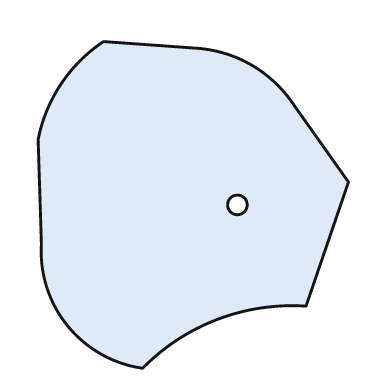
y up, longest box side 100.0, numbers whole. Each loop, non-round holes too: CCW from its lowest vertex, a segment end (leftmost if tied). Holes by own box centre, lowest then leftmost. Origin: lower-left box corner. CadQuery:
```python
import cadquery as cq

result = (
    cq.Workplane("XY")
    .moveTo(32.0, 0.0)
    .threePointArc((55.0, 15.0), (82.0, 19.0))
    .lineTo(95.0, 57.0)
    .lineTo(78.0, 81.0)
    .threePointArc((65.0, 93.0), (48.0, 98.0))
    .lineTo(20.0, 100.0)
    .threePointArc((7.0, 87.0), (0.0, 70.0))
    .lineTo(1.0, 38.0)
    .threePointArc((9.0, 13.0), (32.0, 0.0))
    .close()
    .moveTo(61.0, 50.0)
    .circle(3.0)
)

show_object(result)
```